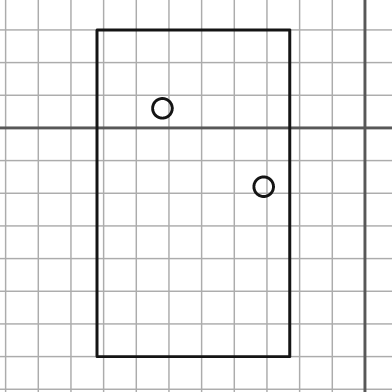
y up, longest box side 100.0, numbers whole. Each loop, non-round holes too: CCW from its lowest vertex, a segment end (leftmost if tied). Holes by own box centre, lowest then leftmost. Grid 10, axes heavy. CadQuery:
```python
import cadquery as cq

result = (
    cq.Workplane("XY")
    .moveTo(-82.0, -70.0)
    .lineTo(-23.0, -70.0)
    .lineTo(-23.0, 30.0)
    .lineTo(-82.0, 30.0)
    .close()
    .moveTo(-31.0, -18.0)
    .circle(3.0)
    .moveTo(-62.0, 6.0)
    .circle(3.0)
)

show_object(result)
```